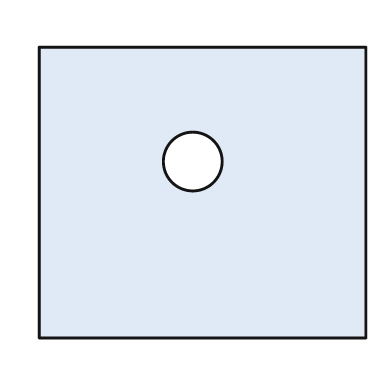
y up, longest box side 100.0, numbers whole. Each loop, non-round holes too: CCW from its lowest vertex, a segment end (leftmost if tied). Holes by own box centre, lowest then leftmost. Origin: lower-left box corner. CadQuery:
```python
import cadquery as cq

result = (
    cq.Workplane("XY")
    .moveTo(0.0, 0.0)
    .lineTo(100.0, 0.0)
    .lineTo(100.0, 89.0)
    .lineTo(0.0, 89.0)
    .close()
    .moveTo(47.0, 54.0)
    .circle(9.0)
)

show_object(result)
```